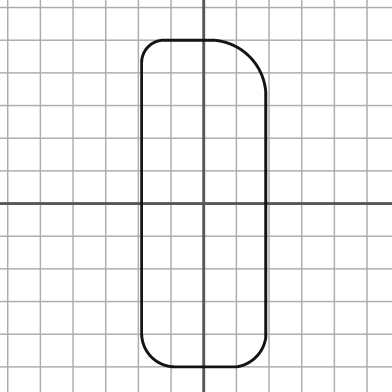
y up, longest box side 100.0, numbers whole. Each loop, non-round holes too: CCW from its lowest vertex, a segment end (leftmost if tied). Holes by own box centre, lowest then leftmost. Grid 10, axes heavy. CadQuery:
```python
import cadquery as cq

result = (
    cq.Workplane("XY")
    .moveTo(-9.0, -50.0)
    .lineTo(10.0, -50.0)
    .threePointArc((16.0, -47.0), (19.0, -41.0))
    .lineTo(19.0, 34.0)
    .threePointArc((14.0, 45.0), (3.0, 50.0))
    .lineTo(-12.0, 50.0)
    .threePointArc((-17.0, 48.0), (-19.0, 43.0))
    .lineTo(-19.0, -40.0)
    .threePointArc((-16.0, -47.0), (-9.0, -50.0))
    .close()
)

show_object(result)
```